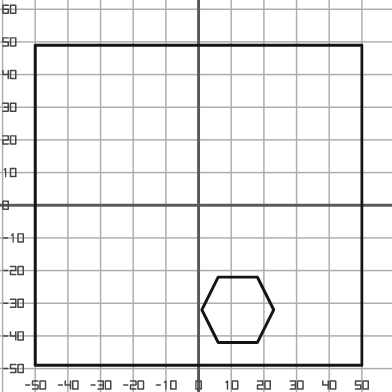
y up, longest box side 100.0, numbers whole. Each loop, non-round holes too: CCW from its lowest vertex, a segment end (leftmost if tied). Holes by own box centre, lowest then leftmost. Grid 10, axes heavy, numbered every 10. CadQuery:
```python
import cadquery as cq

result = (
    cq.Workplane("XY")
    .moveTo(-50.0, -49.0)
    .lineTo(50.0, -49.0)
    .lineTo(50.0, 49.0)
    .lineTo(-50.0, 49.0)
    .close()
    .moveTo(6.0, -42.0)
    .lineTo(18.0, -42.0)
    .lineTo(23.0, -32.0)
    .lineTo(18.0, -22.0)
    .lineTo(6.0, -22.0)
    .lineTo(1.0, -32.0)
    .close()
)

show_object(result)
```